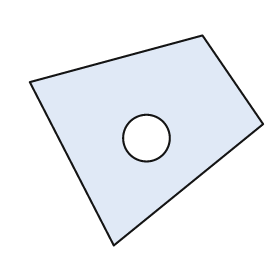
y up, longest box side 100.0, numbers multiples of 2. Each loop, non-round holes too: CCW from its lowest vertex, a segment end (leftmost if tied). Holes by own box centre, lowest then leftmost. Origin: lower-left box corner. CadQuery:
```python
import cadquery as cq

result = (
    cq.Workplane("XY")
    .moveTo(36.0, 0.0)
    .lineTo(100.0, 52.0)
    .lineTo(74.0, 90.0)
    .lineTo(0.0, 70.0)
    .close()
    .moveTo(50.0, 46.0)
    .circle(10.0)
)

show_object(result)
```